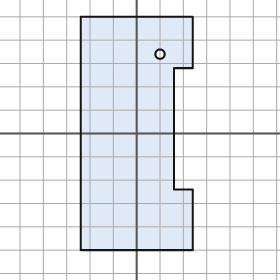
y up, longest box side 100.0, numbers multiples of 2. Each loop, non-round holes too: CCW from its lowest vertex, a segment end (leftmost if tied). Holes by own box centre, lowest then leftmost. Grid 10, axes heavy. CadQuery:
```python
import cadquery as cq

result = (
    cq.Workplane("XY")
    .moveTo(-24.0, -50.0)
    .lineTo(24.0, -50.0)
    .lineTo(24.0, -24.0)
    .lineTo(16.0, -24.0)
    .lineTo(16.0, 28.0)
    .lineTo(24.0, 28.0)
    .lineTo(24.0, 50.0)
    .lineTo(-24.0, 50.0)
    .close()
    .moveTo(10.0, 34.0)
    .circle(2.0)
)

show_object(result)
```